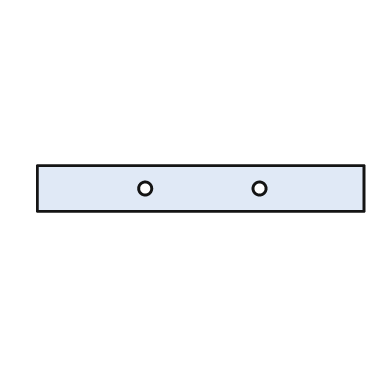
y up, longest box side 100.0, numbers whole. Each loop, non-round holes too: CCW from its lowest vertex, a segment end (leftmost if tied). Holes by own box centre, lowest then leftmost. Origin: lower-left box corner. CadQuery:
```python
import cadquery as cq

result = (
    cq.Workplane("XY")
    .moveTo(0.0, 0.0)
    .lineTo(100.0, 0.0)
    .lineTo(100.0, 14.0)
    .lineTo(0.0, 14.0)
    .close()
    .moveTo(33.0, 7.0)
    .circle(2.0)
    .moveTo(68.0, 7.0)
    .circle(2.0)
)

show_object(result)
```